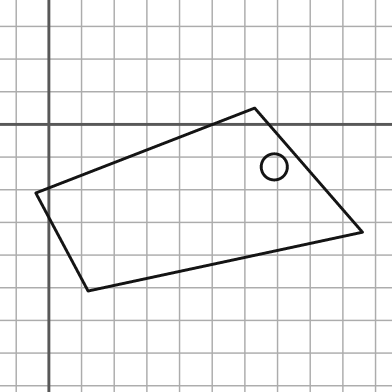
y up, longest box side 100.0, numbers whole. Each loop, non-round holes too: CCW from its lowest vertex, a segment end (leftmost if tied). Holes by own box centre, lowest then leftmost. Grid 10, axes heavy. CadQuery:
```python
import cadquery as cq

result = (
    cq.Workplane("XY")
    .moveTo(12.0, -51.0)
    .lineTo(96.0, -33.0)
    .lineTo(63.0, 5.0)
    .lineTo(-4.0, -21.0)
    .close()
    .moveTo(69.0, -13.0)
    .circle(4.0)
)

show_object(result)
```